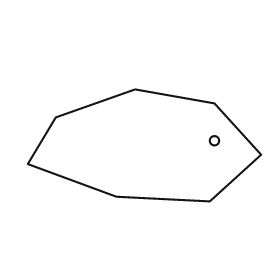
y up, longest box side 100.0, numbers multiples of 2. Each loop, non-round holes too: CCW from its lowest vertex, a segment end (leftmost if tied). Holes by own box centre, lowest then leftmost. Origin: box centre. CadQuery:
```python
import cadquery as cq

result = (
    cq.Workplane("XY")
    .moveTo(28.0, -24.0)
    .lineTo(50.0, -4.0)
    .lineTo(30.0, 18.0)
    .lineTo(-4.0, 24.0)
    .lineTo(-38.0, 12.0)
    .lineTo(-50.0, -8.0)
    .lineTo(-12.0, -22.0)
    .close()
    .moveTo(30.0, 2.0)
    .circle(2.0)
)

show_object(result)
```